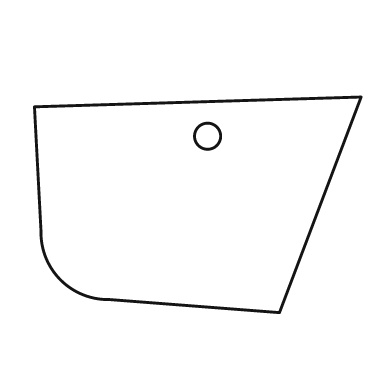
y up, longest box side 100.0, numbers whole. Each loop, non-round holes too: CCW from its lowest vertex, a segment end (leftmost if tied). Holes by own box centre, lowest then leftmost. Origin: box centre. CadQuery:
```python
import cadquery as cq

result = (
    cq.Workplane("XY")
    .moveTo(25.0, -33.0)
    .lineTo(50.0, 33.0)
    .lineTo(-50.0, 30.0)
    .lineTo(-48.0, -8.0)
    .threePointArc((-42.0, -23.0), (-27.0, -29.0))
    .close()
    .moveTo(3.0, 21.0)
    .circle(4.0)
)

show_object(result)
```